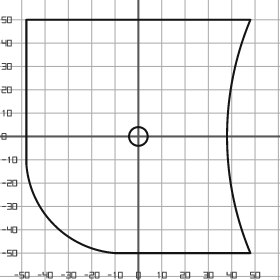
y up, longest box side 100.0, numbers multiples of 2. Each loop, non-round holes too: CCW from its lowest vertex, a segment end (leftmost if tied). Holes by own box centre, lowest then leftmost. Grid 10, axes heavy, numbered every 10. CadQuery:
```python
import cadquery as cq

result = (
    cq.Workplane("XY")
    .moveTo(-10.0, -50.0)
    .lineTo(48.0, -50.0)
    .threePointArc((38.0, 0.0), (48.0, 50.0))
    .lineTo(-48.0, 50.0)
    .lineTo(-48.0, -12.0)
    .threePointArc((-36.0, -38.0), (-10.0, -50.0))
    .close()
    .moveTo(0.0, 0.0)
    .circle(4.0)
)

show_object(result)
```